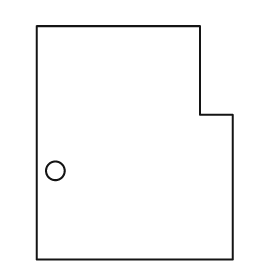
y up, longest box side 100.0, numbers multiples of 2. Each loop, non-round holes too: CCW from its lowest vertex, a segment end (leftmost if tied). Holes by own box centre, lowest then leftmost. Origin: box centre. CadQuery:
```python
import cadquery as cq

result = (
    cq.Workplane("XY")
    .moveTo(-42.0, -50.0)
    .lineTo(42.0, -50.0)
    .lineTo(42.0, 12.0)
    .lineTo(28.0, 12.0)
    .lineTo(28.0, 50.0)
    .lineTo(-42.0, 50.0)
    .close()
    .moveTo(-34.0, -12.0)
    .circle(4.0)
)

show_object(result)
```